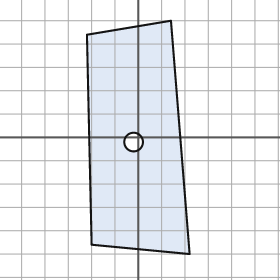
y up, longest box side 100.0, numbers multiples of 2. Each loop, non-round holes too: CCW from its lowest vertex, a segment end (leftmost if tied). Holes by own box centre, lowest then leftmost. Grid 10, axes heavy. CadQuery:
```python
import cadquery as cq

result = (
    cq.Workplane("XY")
    .moveTo(22.0, -50.0)
    .lineTo(14.0, 50.0)
    .lineTo(-22.0, 44.0)
    .lineTo(-20.0, -46.0)
    .close()
    .moveTo(-2.0, -2.0)
    .circle(4.0)
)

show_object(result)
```